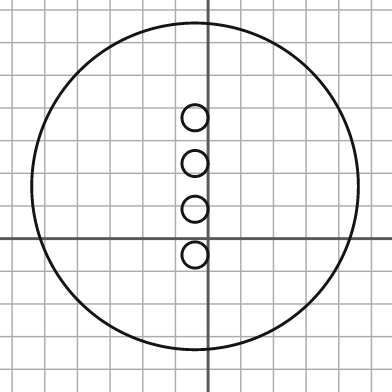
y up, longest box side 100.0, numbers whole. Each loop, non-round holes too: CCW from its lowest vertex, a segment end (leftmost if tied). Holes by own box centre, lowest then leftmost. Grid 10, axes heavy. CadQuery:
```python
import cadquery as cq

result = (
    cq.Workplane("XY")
    .moveTo(-4.0, 16.0)
    .circle(50.0)
    .moveTo(-4.0, -5.0)
    .circle(4.0)
    .moveTo(-4.0, 9.0)
    .circle(4.0)
    .moveTo(-4.0, 23.0)
    .circle(4.0)
    .moveTo(-4.0, 37.0)
    .circle(4.0)
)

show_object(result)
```